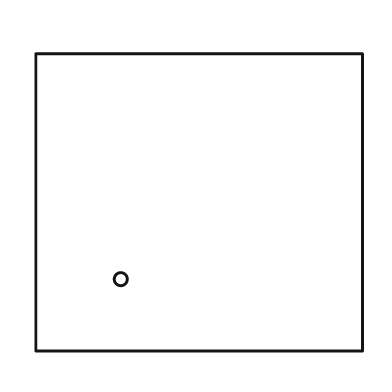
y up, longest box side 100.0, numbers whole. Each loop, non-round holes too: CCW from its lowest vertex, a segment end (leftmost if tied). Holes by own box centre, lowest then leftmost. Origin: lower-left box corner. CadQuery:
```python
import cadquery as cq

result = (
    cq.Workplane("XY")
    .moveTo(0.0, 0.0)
    .lineTo(100.0, 0.0)
    .lineTo(100.0, 91.0)
    .lineTo(0.0, 91.0)
    .close()
    .moveTo(26.0, 22.0)
    .circle(2.0)
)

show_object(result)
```